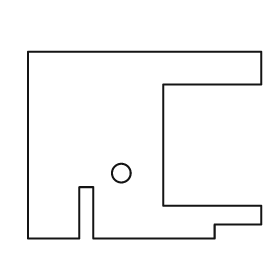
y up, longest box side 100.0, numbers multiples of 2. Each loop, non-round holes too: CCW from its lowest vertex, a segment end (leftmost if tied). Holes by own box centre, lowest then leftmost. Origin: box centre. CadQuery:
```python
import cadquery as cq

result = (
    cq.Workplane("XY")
    .moveTo(-50.0, -40.0)
    .lineTo(-28.0, -40.0)
    .lineTo(-28.0, -18.0)
    .lineTo(-22.0, -18.0)
    .lineTo(-22.0, -40.0)
    .lineTo(30.0, -40.0)
    .lineTo(30.0, -34.0)
    .lineTo(50.0, -34.0)
    .lineTo(50.0, -26.0)
    .lineTo(8.0, -26.0)
    .lineTo(8.0, 26.0)
    .lineTo(50.0, 26.0)
    .lineTo(50.0, 40.0)
    .lineTo(-50.0, 40.0)
    .close()
    .moveTo(-10.0, -12.0)
    .circle(4.0)
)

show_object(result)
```